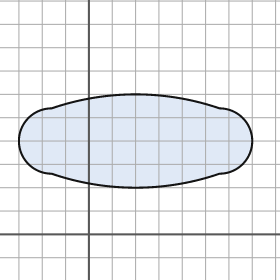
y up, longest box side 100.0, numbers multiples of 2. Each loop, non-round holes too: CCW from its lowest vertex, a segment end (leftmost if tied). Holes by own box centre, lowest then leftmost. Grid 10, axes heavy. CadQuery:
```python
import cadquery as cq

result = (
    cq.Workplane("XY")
    .moveTo(-16.0, 26.0)
    .threePointArc((20.0, 20.0), (56.0, 26.0))
    .threePointArc((70.0, 40.0), (56.0, 54.0))
    .threePointArc((20.0, 60.0), (-16.0, 54.0))
    .threePointArc((-30.0, 40.0), (-16.0, 26.0))
    .close()
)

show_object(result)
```